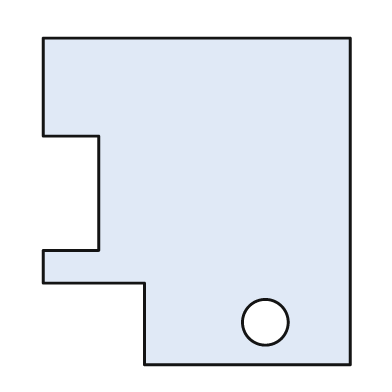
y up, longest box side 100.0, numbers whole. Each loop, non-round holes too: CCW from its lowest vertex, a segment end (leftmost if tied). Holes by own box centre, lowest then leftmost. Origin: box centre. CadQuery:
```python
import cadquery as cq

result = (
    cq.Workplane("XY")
    .moveTo(-16.0, -50.0)
    .lineTo(47.0, -50.0)
    .lineTo(47.0, 50.0)
    .lineTo(-47.0, 50.0)
    .lineTo(-47.0, 20.0)
    .lineTo(-30.0, 20.0)
    .lineTo(-30.0, -15.0)
    .lineTo(-47.0, -15.0)
    .lineTo(-47.0, -25.0)
    .lineTo(-16.0, -25.0)
    .close()
    .moveTo(21.0, -37.0)
    .circle(7.0)
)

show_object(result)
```